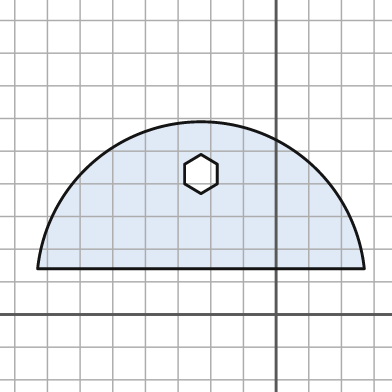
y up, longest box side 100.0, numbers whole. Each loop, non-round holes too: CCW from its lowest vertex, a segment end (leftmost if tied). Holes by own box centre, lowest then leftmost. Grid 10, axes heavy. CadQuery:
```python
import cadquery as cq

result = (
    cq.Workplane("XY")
    .moveTo(-73.0, 14.0)
    .lineTo(27.0, 14.0)
    .threePointArc((-23.0, 59.0), (-73.0, 14.0))
    .close()
    .moveTo(-23.0, 37.0)
    .lineTo(-18.0, 40.0)
    .lineTo(-18.0, 46.0)
    .lineTo(-23.0, 49.0)
    .lineTo(-28.0, 46.0)
    .lineTo(-28.0, 40.0)
    .close()
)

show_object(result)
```